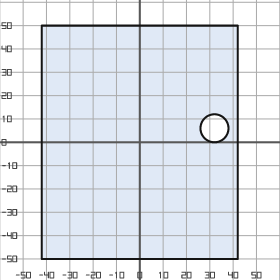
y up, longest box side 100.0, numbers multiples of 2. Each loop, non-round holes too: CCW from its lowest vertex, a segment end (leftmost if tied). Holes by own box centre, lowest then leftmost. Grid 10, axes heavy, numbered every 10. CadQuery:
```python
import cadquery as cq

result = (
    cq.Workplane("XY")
    .moveTo(-42.0, -50.0)
    .lineTo(42.0, -50.0)
    .lineTo(42.0, 50.0)
    .lineTo(-42.0, 50.0)
    .close()
    .moveTo(32.0, 6.0)
    .circle(6.0)
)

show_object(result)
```